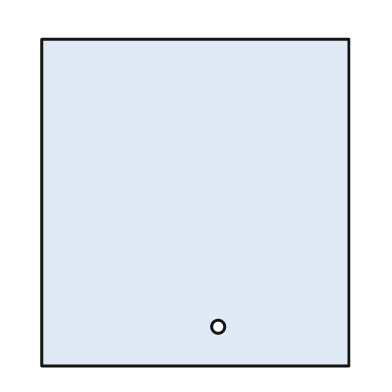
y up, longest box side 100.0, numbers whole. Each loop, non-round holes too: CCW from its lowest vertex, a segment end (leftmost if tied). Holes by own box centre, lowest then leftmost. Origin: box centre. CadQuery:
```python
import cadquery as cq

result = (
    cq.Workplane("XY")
    .moveTo(-47.0, -50.0)
    .lineTo(47.0, -50.0)
    .lineTo(47.0, 50.0)
    .lineTo(-47.0, 50.0)
    .close()
    .moveTo(7.0, -38.0)
    .circle(2.0)
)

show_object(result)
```